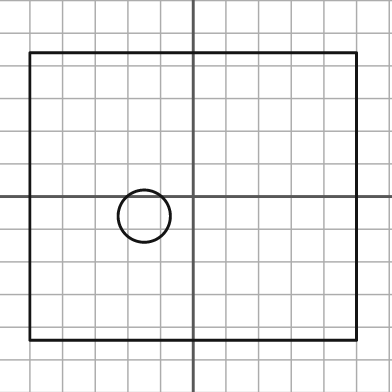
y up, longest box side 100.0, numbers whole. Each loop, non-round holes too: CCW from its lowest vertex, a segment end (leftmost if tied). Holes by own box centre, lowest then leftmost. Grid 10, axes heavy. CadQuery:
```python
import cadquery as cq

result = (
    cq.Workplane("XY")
    .moveTo(-50.0, -44.0)
    .lineTo(50.0, -44.0)
    .lineTo(50.0, 44.0)
    .lineTo(-50.0, 44.0)
    .close()
    .moveTo(-15.0, -6.0)
    .circle(8.0)
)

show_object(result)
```